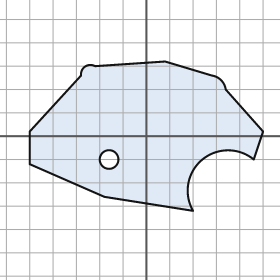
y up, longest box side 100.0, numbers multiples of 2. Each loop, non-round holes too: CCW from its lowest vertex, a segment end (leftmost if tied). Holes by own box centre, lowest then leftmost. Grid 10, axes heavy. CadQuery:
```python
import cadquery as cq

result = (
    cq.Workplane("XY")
    .moveTo(20.0, -32.0)
    .threePointArc((24.0, -10.0), (46.0, -10.0))
    .lineTo(50.0, 2.0)
    .lineTo(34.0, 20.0)
    .threePointArc((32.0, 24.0), (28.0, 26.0))
    .lineTo(8.0, 32.0)
    .lineTo(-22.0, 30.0)
    .threePointArc((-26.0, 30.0), (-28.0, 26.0))
    .lineTo(-50.0, 2.0)
    .lineTo(-50.0, -12.0)
    .lineTo(-18.0, -26.0)
    .close()
    .moveTo(-16.0, -10.0)
    .circle(4.0)
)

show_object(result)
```